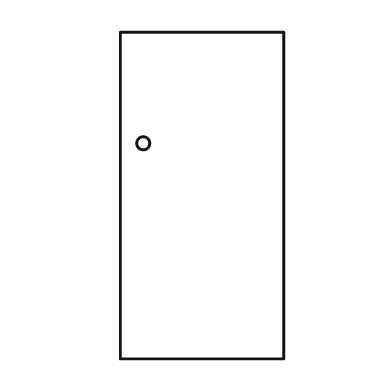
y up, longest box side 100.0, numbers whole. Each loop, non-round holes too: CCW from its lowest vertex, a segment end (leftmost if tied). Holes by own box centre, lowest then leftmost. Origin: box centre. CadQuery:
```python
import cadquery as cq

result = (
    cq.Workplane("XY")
    .moveTo(-25.0, -50.0)
    .lineTo(25.0, -50.0)
    .lineTo(25.0, 50.0)
    .lineTo(-25.0, 50.0)
    .close()
    .moveTo(-18.0, 16.0)
    .circle(2.0)
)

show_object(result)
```